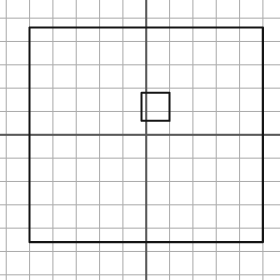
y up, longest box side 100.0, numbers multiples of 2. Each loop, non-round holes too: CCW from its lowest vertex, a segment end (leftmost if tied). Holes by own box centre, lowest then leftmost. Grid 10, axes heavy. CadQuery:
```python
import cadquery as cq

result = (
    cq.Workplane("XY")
    .moveTo(-50.0, -46.0)
    .lineTo(50.0, -46.0)
    .lineTo(50.0, 46.0)
    .lineTo(-50.0, 46.0)
    .close()
    .moveTo(-2.0, 6.0)
    .lineTo(10.0, 6.0)
    .lineTo(10.0, 18.0)
    .lineTo(-2.0, 18.0)
    .close()
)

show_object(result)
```